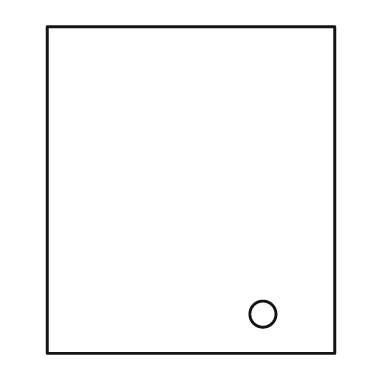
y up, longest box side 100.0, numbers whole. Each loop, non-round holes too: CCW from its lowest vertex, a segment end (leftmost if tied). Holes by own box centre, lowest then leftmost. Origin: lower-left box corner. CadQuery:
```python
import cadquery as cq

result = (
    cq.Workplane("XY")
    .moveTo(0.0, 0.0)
    .lineTo(88.0, 0.0)
    .lineTo(88.0, 100.0)
    .lineTo(0.0, 100.0)
    .close()
    .moveTo(66.0, 12.0)
    .circle(4.0)
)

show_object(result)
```